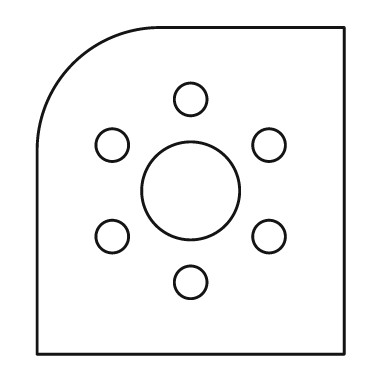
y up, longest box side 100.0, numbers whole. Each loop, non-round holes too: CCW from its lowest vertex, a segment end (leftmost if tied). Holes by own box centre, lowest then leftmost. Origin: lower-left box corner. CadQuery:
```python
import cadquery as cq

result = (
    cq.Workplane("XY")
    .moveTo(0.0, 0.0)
    .lineTo(94.0, 0.0)
    .lineTo(94.0, 100.0)
    .lineTo(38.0, 100.0)
    .threePointArc((11.0, 89.0), (0.0, 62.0))
    .close()
    .moveTo(47.0, 22.0)
    .circle(5.0)
    .moveTo(23.0, 36.0)
    .circle(5.0)
    .moveTo(71.0, 36.0)
    .circle(5.0)
    .moveTo(47.0, 50.0)
    .circle(15.0)
    .moveTo(23.0, 64.0)
    .circle(5.0)
    .moveTo(71.0, 64.0)
    .circle(5.0)
    .moveTo(47.0, 78.0)
    .circle(5.0)
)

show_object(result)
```